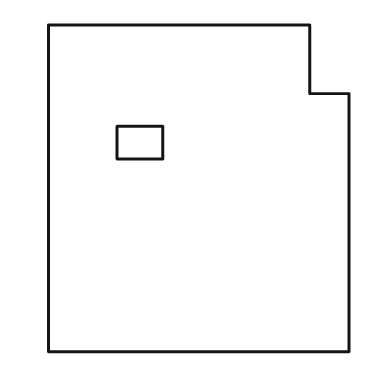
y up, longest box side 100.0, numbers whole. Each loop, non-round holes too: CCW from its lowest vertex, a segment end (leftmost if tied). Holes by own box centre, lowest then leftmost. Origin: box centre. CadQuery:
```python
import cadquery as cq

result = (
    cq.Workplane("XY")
    .moveTo(-46.0, -50.0)
    .lineTo(46.0, -50.0)
    .lineTo(46.0, 29.0)
    .lineTo(34.0, 29.0)
    .lineTo(34.0, 50.0)
    .lineTo(-46.0, 50.0)
    .close()
    .moveTo(-25.0, 9.0)
    .lineTo(-11.0, 9.0)
    .lineTo(-11.0, 19.0)
    .lineTo(-25.0, 19.0)
    .close()
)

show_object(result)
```